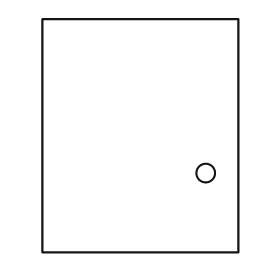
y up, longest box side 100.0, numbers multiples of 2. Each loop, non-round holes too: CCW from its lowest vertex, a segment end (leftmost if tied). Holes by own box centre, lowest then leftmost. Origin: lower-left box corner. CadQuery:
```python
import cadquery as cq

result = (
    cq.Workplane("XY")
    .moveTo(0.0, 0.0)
    .lineTo(84.0, 0.0)
    .lineTo(84.0, 100.0)
    .lineTo(0.0, 100.0)
    .close()
    .moveTo(70.0, 34.0)
    .circle(4.0)
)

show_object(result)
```